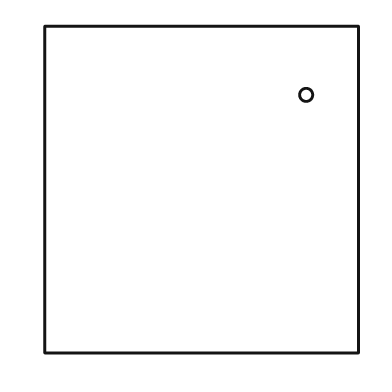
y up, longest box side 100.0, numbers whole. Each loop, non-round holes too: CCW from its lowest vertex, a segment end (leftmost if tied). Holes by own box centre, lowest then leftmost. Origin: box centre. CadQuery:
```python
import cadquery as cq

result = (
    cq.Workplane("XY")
    .moveTo(-48.0, -50.0)
    .lineTo(48.0, -50.0)
    .lineTo(48.0, 50.0)
    .lineTo(-48.0, 50.0)
    .close()
    .moveTo(32.0, 29.0)
    .circle(2.0)
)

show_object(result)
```